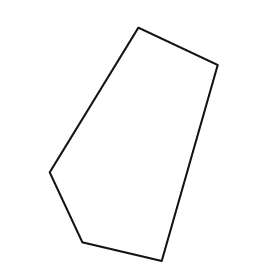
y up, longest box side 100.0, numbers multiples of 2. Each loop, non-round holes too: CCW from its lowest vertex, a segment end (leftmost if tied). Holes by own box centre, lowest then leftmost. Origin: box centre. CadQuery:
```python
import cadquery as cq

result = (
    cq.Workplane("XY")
    .moveTo(12.0, -50.0)
    .lineTo(36.0, 34.0)
    .lineTo(2.0, 50.0)
    .lineTo(-36.0, -12.0)
    .lineTo(-22.0, -42.0)
    .close()
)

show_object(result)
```